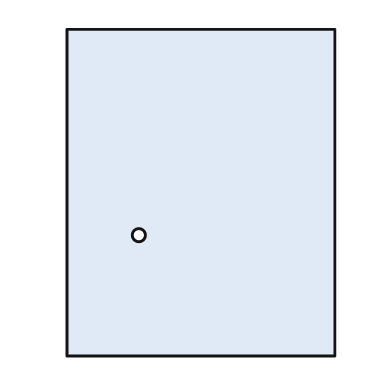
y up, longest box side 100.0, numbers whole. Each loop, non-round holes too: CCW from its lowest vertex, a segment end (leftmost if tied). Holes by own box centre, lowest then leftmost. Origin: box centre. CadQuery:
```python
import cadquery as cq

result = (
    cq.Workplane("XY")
    .moveTo(-41.0, -50.0)
    .lineTo(41.0, -50.0)
    .lineTo(41.0, 50.0)
    .lineTo(-41.0, 50.0)
    .close()
    .moveTo(-19.0, -13.0)
    .circle(2.0)
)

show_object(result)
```